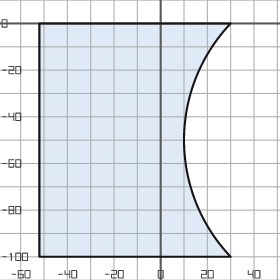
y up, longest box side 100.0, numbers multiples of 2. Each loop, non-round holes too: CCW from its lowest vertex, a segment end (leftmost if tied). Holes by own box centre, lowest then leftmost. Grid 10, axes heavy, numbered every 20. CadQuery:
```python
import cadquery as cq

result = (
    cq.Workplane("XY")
    .moveTo(-52.0, -100.0)
    .lineTo(30.0, -100.0)
    .threePointArc((10.0, -50.0), (30.0, 0.0))
    .lineTo(-52.0, 0.0)
    .close()
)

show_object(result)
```